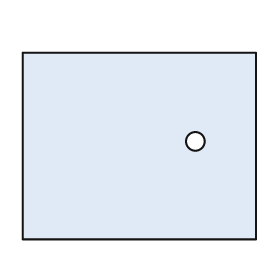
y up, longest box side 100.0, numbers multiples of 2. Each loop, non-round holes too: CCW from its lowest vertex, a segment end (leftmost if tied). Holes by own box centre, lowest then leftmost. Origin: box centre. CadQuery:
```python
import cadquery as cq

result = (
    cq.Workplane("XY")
    .moveTo(-50.0, -40.0)
    .lineTo(50.0, -40.0)
    .lineTo(50.0, 40.0)
    .lineTo(-50.0, 40.0)
    .close()
    .moveTo(24.0, 2.0)
    .circle(4.0)
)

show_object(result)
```